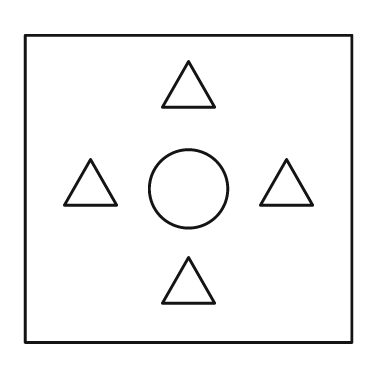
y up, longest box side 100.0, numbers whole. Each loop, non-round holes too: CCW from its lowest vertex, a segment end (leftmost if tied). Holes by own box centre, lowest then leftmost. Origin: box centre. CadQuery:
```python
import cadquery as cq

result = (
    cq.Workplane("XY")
    .moveTo(-50.0, -47.0)
    .lineTo(50.0, -47.0)
    .lineTo(50.0, 47.0)
    .lineTo(-50.0, 47.0)
    .close()
    .moveTo(-8.0, -35.0)
    .lineTo(8.0, -35.0)
    .lineTo(0.0, -21.0)
    .close()
    .moveTo(0.0, 0.0)
    .circle(12.0)
    .moveTo(-38.0, -5.0)
    .lineTo(-22.0, -5.0)
    .lineTo(-30.0, 9.0)
    .close()
    .moveTo(22.0, -5.0)
    .lineTo(38.0, -5.0)
    .lineTo(30.0, 9.0)
    .close()
    .moveTo(-8.0, 25.0)
    .lineTo(8.0, 25.0)
    .lineTo(0.0, 39.0)
    .close()
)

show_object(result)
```